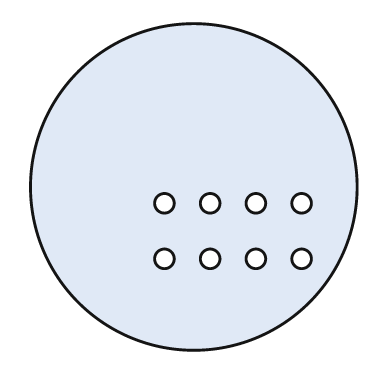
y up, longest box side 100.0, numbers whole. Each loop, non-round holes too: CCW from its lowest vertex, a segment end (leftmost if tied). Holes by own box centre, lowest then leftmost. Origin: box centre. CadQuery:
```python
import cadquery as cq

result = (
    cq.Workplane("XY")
    .moveTo(0.0, 0.0)
    .circle(50.0)
    .moveTo(-9.0, -22.0)
    .circle(3.0)
    .moveTo(5.0, -22.0)
    .circle(3.0)
    .moveTo(19.0, -22.0)
    .circle(3.0)
    .moveTo(33.0, -22.0)
    .circle(3.0)
    .moveTo(-9.0, -5.0)
    .circle(3.0)
    .moveTo(5.0, -5.0)
    .circle(3.0)
    .moveTo(19.0, -5.0)
    .circle(3.0)
    .moveTo(33.0, -5.0)
    .circle(3.0)
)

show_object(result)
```